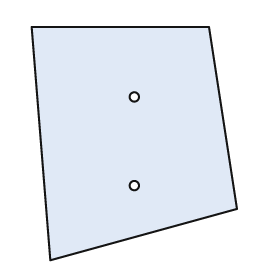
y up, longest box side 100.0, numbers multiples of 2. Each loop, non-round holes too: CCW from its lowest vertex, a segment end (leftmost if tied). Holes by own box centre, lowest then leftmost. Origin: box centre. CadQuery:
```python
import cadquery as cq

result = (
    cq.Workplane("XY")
    .moveTo(-36.0, -50.0)
    .lineTo(44.0, -28.0)
    .lineTo(32.0, 50.0)
    .lineTo(-44.0, 50.0)
    .close()
    .moveTo(0.0, -18.0)
    .circle(2.0)
    .moveTo(0.0, 20.0)
    .circle(2.0)
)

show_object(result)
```